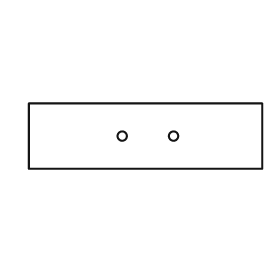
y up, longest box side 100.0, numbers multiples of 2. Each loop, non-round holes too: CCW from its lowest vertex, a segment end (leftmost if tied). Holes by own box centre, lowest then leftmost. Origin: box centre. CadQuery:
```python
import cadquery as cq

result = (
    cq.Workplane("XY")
    .moveTo(-50.0, -14.0)
    .lineTo(50.0, -14.0)
    .lineTo(50.0, 14.0)
    .lineTo(-50.0, 14.0)
    .close()
    .moveTo(-10.0, 0.0)
    .circle(2.0)
    .moveTo(12.0, 0.0)
    .circle(2.0)
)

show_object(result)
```